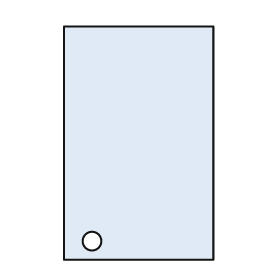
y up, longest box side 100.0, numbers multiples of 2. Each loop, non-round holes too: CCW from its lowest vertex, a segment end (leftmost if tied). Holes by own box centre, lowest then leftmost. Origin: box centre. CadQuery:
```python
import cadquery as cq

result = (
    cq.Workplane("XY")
    .moveTo(-32.0, -50.0)
    .lineTo(32.0, -50.0)
    .lineTo(32.0, 50.0)
    .lineTo(-32.0, 50.0)
    .close()
    .moveTo(-20.0, -42.0)
    .circle(4.0)
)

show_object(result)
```